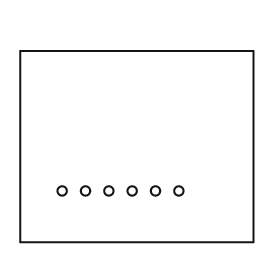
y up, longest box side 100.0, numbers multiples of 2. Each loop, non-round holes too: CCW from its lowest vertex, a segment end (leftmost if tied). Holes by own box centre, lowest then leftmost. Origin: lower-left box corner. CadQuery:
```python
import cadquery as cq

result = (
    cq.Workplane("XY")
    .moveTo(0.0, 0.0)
    .lineTo(100.0, 0.0)
    .lineTo(100.0, 82.0)
    .lineTo(0.0, 82.0)
    .close()
    .moveTo(18.0, 22.0)
    .circle(2.0)
    .moveTo(28.0, 22.0)
    .circle(2.0)
    .moveTo(38.0, 22.0)
    .circle(2.0)
    .moveTo(48.0, 22.0)
    .circle(2.0)
    .moveTo(58.0, 22.0)
    .circle(2.0)
    .moveTo(68.0, 22.0)
    .circle(2.0)
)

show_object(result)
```